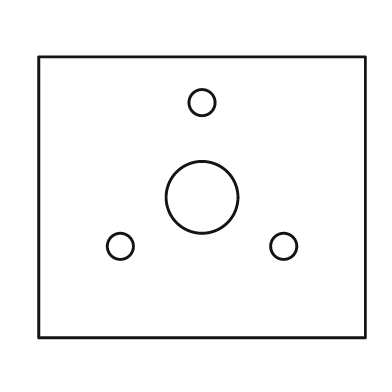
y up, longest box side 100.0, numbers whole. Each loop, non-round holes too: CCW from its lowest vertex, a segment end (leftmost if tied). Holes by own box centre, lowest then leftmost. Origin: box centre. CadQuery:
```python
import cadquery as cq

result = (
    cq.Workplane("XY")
    .moveTo(-50.0, -43.0)
    .lineTo(50.0, -43.0)
    .lineTo(50.0, 43.0)
    .lineTo(-50.0, 43.0)
    .close()
    .moveTo(-25.0, -15.0)
    .circle(4.0)
    .moveTo(25.0, -15.0)
    .circle(4.0)
    .moveTo(0.0, 0.0)
    .circle(11.0)
    .moveTo(0.0, 29.0)
    .circle(4.0)
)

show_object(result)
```